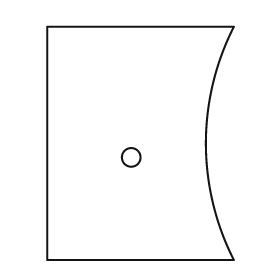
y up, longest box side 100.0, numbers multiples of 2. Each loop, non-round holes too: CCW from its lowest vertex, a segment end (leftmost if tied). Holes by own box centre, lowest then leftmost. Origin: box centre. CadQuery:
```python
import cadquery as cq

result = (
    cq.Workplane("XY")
    .moveTo(-40.0, -50.0)
    .lineTo(40.0, -50.0)
    .threePointArc((28.0, 0.0), (40.0, 50.0))
    .lineTo(-40.0, 50.0)
    .close()
    .moveTo(-4.0, -6.0)
    .circle(4.0)
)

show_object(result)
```